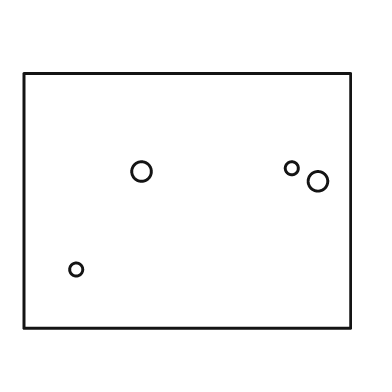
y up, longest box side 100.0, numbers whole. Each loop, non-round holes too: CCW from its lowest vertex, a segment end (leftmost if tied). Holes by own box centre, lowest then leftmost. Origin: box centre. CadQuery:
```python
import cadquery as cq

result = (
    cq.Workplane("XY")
    .moveTo(-50.0, -39.0)
    .lineTo(50.0, -39.0)
    .lineTo(50.0, 39.0)
    .lineTo(-50.0, 39.0)
    .close()
    .moveTo(-34.0, -21.0)
    .circle(2.0)
    .moveTo(40.0, 6.0)
    .circle(3.0)
    .moveTo(-14.0, 9.0)
    .circle(3.0)
    .moveTo(32.0, 10.0)
    .circle(2.0)
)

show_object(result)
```